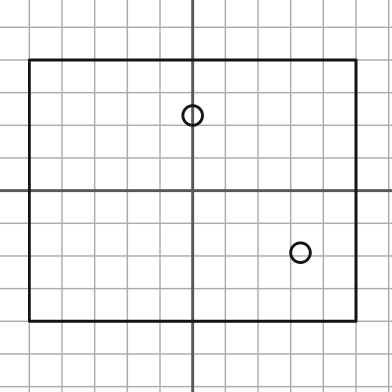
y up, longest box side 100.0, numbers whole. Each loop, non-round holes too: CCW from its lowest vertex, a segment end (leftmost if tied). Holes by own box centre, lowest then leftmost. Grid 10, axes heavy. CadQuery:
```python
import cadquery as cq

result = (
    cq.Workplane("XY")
    .moveTo(-50.0, -40.0)
    .lineTo(50.0, -40.0)
    .lineTo(50.0, 40.0)
    .lineTo(-50.0, 40.0)
    .close()
    .moveTo(33.0, -19.0)
    .circle(3.0)
    .moveTo(0.0, 23.0)
    .circle(3.0)
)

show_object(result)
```